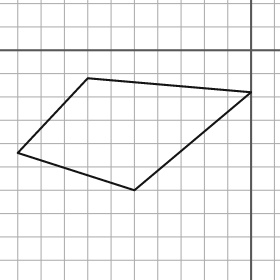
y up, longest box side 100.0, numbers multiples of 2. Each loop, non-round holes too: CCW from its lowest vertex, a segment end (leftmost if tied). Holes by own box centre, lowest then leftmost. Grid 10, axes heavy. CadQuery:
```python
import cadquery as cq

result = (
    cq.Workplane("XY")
    .moveTo(-50.0, -60.0)
    .lineTo(0.0, -18.0)
    .lineTo(-70.0, -12.0)
    .lineTo(-100.0, -44.0)
    .close()
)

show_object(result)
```